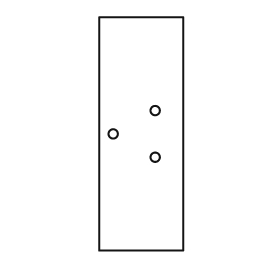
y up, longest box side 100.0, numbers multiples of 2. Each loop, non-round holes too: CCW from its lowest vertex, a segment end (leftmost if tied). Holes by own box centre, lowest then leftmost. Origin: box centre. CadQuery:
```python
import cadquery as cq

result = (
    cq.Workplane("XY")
    .moveTo(-18.0, -50.0)
    .lineTo(18.0, -50.0)
    .lineTo(18.0, 50.0)
    .lineTo(-18.0, 50.0)
    .close()
    .moveTo(6.0, -10.0)
    .circle(2.0)
    .moveTo(-12.0, 0.0)
    .circle(2.0)
    .moveTo(6.0, 10.0)
    .circle(2.0)
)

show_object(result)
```